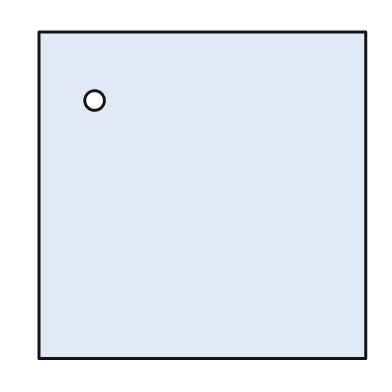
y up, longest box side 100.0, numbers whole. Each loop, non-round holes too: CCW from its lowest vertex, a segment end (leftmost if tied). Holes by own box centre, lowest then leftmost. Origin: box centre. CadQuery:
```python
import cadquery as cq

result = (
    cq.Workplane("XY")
    .moveTo(-50.0, -50.0)
    .lineTo(50.0, -50.0)
    .lineTo(50.0, 50.0)
    .lineTo(-50.0, 50.0)
    .close()
    .moveTo(-33.0, 29.0)
    .circle(3.0)
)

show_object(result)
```